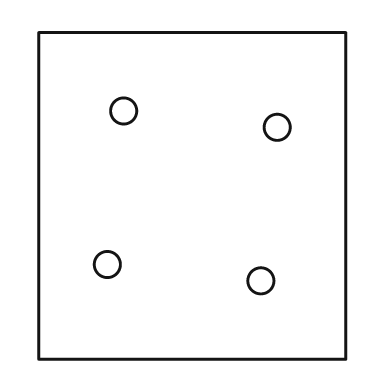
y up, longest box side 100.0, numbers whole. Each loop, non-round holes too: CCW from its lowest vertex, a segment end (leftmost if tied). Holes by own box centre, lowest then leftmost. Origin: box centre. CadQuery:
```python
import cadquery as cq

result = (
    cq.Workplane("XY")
    .moveTo(-47.0, -50.0)
    .lineTo(47.0, -50.0)
    .lineTo(47.0, 50.0)
    .lineTo(-47.0, 50.0)
    .close()
    .moveTo(21.0, -26.0)
    .circle(4.0)
    .moveTo(-26.0, -21.0)
    .circle(4.0)
    .moveTo(26.0, 21.0)
    .circle(4.0)
    .moveTo(-21.0, 26.0)
    .circle(4.0)
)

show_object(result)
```